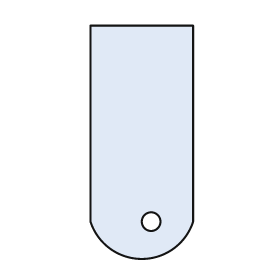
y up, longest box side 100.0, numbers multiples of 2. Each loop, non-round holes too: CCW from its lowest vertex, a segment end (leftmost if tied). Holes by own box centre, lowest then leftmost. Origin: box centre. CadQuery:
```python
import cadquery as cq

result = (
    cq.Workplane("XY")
    .moveTo(-22.0, -34.0)
    .threePointArc((0.0, -50.0), (22.0, -34.0))
    .lineTo(22.0, 50.0)
    .lineTo(-22.0, 50.0)
    .close()
    .moveTo(4.0, -34.0)
    .circle(4.0)
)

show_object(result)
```